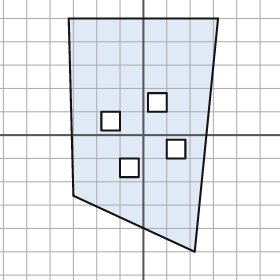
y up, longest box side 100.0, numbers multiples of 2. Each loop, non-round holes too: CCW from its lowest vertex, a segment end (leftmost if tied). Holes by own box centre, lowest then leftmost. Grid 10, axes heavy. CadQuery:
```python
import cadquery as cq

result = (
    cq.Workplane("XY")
    .moveTo(22.0, -50.0)
    .lineTo(32.0, 50.0)
    .lineTo(-32.0, 50.0)
    .lineTo(-30.0, -26.0)
    .close()
    .moveTo(-10.0, -18.0)
    .lineTo(-2.0, -18.0)
    .lineTo(-2.0, -10.0)
    .lineTo(-10.0, -10.0)
    .close()
    .moveTo(10.0, -10.0)
    .lineTo(18.0, -10.0)
    .lineTo(18.0, -2.0)
    .lineTo(10.0, -2.0)
    .close()
    .moveTo(-18.0, 2.0)
    .lineTo(-10.0, 2.0)
    .lineTo(-10.0, 10.0)
    .lineTo(-18.0, 10.0)
    .close()
    .moveTo(2.0, 10.0)
    .lineTo(10.0, 10.0)
    .lineTo(10.0, 18.0)
    .lineTo(2.0, 18.0)
    .close()
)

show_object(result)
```